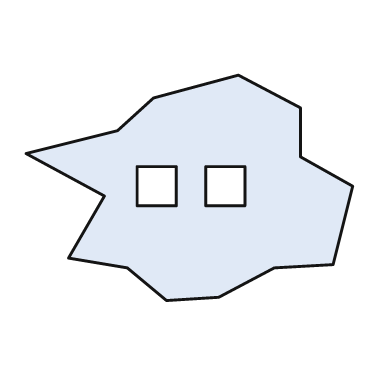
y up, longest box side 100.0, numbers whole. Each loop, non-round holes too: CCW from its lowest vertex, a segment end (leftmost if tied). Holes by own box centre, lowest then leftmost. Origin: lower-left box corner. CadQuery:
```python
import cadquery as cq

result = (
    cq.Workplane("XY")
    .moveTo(43.0, 0.0)
    .lineTo(59.0, 1.0)
    .lineTo(76.0, 10.0)
    .lineTo(94.0, 11.0)
    .lineTo(100.0, 35.0)
    .lineTo(84.0, 44.0)
    .lineTo(84.0, 59.0)
    .lineTo(65.0, 69.0)
    .lineTo(39.0, 62.0)
    .lineTo(28.0, 52.0)
    .lineTo(0.0, 45.0)
    .lineTo(24.0, 32.0)
    .lineTo(13.0, 13.0)
    .lineTo(31.0, 10.0)
    .close()
    .moveTo(34.0, 29.0)
    .lineTo(46.0, 29.0)
    .lineTo(46.0, 41.0)
    .lineTo(34.0, 41.0)
    .close()
    .moveTo(55.0, 29.0)
    .lineTo(67.0, 29.0)
    .lineTo(67.0, 41.0)
    .lineTo(55.0, 41.0)
    .close()
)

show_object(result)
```